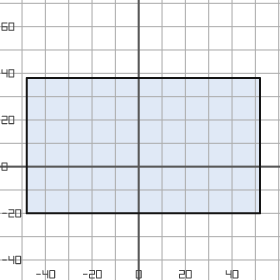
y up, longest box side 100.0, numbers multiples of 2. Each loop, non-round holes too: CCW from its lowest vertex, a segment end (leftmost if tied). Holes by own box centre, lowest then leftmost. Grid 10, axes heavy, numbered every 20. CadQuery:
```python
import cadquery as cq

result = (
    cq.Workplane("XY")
    .moveTo(-48.0, -20.0)
    .lineTo(52.0, -20.0)
    .lineTo(52.0, 38.0)
    .lineTo(-48.0, 38.0)
    .close()
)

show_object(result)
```